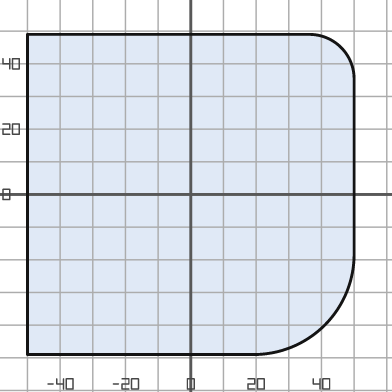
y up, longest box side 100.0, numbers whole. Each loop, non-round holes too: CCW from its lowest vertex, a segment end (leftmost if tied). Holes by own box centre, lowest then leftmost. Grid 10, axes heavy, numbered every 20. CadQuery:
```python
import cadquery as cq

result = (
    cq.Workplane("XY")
    .moveTo(-50.0, -49.0)
    .lineTo(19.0, -49.0)
    .threePointArc((41.0, -40.0), (50.0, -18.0))
    .lineTo(50.0, 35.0)
    .threePointArc((46.0, 45.0), (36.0, 49.0))
    .lineTo(-50.0, 49.0)
    .close()
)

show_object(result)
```